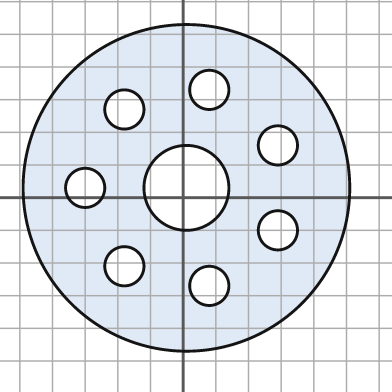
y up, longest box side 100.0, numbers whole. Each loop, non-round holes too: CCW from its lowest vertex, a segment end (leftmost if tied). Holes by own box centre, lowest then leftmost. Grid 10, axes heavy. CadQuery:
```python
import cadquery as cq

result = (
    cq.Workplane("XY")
    .moveTo(1.0, 3.0)
    .circle(50.0)
    .moveTo(8.0, -27.0)
    .circle(6.0)
    .moveTo(-18.0, -21.0)
    .circle(6.0)
    .moveTo(29.0, -10.0)
    .circle(6.0)
    .moveTo(-30.0, 3.0)
    .circle(6.0)
    .moveTo(1.0, 3.0)
    .circle(13.0)
    .moveTo(29.0, 16.0)
    .circle(6.0)
    .moveTo(-18.0, 27.0)
    .circle(6.0)
    .moveTo(8.0, 33.0)
    .circle(6.0)
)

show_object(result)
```